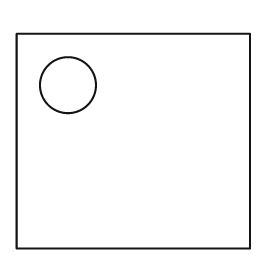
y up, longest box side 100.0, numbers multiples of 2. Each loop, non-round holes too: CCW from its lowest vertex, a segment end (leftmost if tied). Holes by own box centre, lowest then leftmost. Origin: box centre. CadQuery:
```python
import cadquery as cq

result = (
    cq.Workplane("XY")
    .moveTo(-50.0, -46.0)
    .lineTo(50.0, -46.0)
    .lineTo(50.0, 46.0)
    .lineTo(-50.0, 46.0)
    .close()
    .moveTo(-28.0, 24.0)
    .circle(12.0)
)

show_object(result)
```